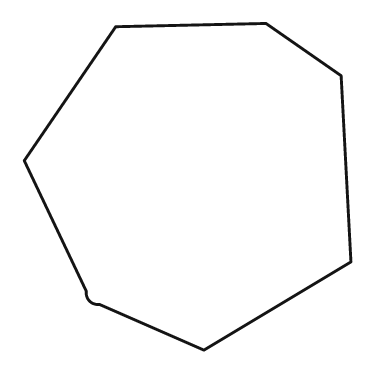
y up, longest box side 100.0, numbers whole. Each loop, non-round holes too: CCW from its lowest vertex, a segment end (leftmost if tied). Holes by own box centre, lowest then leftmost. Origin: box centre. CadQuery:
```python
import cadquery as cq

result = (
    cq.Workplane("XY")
    .moveTo(5.0, -50.0)
    .lineTo(50.0, -23.0)
    .lineTo(47.0, 34.0)
    .lineTo(24.0, 50.0)
    .lineTo(-22.0, 49.0)
    .lineTo(-50.0, 8.0)
    .lineTo(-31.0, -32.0)
    .threePointArc((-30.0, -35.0), (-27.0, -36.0))
    .close()
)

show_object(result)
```